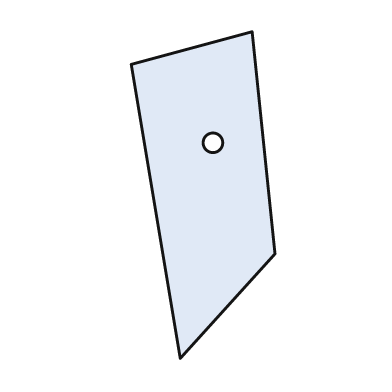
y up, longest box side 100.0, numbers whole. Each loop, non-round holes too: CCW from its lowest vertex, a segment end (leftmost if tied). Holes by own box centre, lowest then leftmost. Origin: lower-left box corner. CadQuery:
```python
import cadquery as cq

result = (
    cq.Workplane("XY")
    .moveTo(15.0, 0.0)
    .lineTo(44.0, 32.0)
    .lineTo(37.0, 100.0)
    .lineTo(0.0, 90.0)
    .close()
    .moveTo(25.0, 66.0)
    .circle(3.0)
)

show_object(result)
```